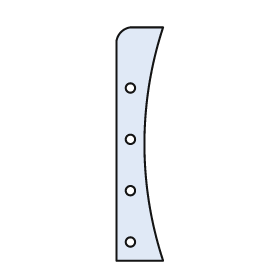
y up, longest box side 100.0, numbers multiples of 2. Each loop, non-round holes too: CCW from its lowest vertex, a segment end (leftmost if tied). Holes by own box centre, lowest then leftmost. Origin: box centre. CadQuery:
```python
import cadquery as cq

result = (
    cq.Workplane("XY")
    .moveTo(-10.0, -50.0)
    .lineTo(10.0, -50.0)
    .threePointArc((2.0, 0.0), (10.0, 50.0))
    .lineTo(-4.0, 50.0)
    .threePointArc((-8.0, 48.0), (-10.0, 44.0))
    .close()
    .moveTo(-4.0, -42.0)
    .circle(2.0)
    .moveTo(-4.0, -20.0)
    .circle(2.0)
    .moveTo(-4.0, 2.0)
    .circle(2.0)
    .moveTo(-4.0, 24.0)
    .circle(2.0)
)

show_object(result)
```